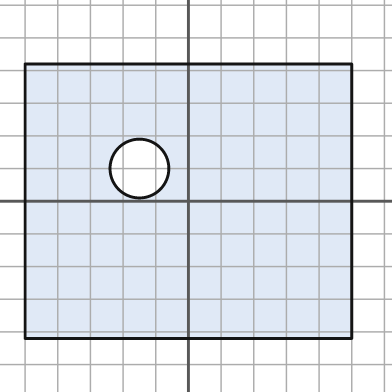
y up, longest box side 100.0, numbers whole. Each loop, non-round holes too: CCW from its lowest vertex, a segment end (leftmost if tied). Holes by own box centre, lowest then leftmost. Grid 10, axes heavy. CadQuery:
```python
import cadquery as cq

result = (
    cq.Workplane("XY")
    .moveTo(-50.0, -42.0)
    .lineTo(50.0, -42.0)
    .lineTo(50.0, 42.0)
    .lineTo(-50.0, 42.0)
    .close()
    .moveTo(-15.0, 10.0)
    .circle(9.0)
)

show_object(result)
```